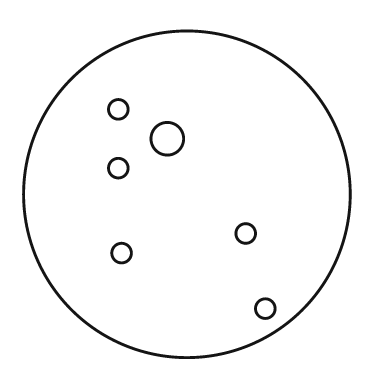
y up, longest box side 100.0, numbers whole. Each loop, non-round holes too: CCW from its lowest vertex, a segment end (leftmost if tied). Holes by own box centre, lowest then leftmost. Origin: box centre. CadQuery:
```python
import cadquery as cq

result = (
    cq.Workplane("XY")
    .moveTo(0.0, 0.0)
    .circle(50.0)
    .moveTo(24.0, -35.0)
    .circle(3.0)
    .moveTo(-20.0, -18.0)
    .circle(3.0)
    .moveTo(18.0, -12.0)
    .circle(3.0)
    .moveTo(-21.0, 8.0)
    .circle(3.0)
    .moveTo(-6.0, 17.0)
    .circle(5.0)
    .moveTo(-21.0, 26.0)
    .circle(3.0)
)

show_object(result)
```